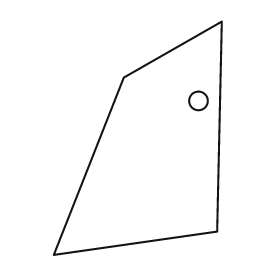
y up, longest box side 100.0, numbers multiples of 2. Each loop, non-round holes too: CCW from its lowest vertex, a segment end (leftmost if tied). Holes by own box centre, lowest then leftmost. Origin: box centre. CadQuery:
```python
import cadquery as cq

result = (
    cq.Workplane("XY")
    .moveTo(-36.0, -50.0)
    .lineTo(34.0, -40.0)
    .lineTo(36.0, 50.0)
    .lineTo(-6.0, 26.0)
    .close()
    .moveTo(26.0, 16.0)
    .circle(4.0)
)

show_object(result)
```